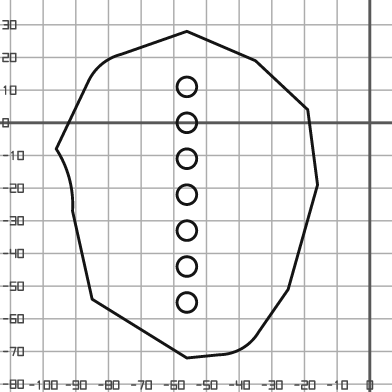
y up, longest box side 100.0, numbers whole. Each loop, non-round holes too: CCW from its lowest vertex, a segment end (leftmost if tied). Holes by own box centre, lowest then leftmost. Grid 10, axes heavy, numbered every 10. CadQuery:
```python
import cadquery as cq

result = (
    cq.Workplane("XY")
    .moveTo(-56.0, -72.0)
    .lineTo(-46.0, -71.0)
    .threePointArc((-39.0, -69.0), (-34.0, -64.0))
    .lineTo(-25.0, -51.0)
    .lineTo(-16.0, -19.0)
    .lineTo(-19.0, 4.0)
    .lineTo(-35.0, 19.0)
    .lineTo(-56.0, 28.0)
    .lineTo(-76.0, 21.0)
    .threePointArc((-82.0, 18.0), (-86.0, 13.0))
    .lineTo(-96.0, -8.0)
    .threePointArc((-92.0, -17.0), (-91.0, -27.0))
    .lineTo(-85.0, -54.0)
    .close()
    .moveTo(-56.0, -55.0)
    .circle(3.0)
    .moveTo(-56.0, -44.0)
    .circle(3.0)
    .moveTo(-56.0, -33.0)
    .circle(3.0)
    .moveTo(-56.0, -22.0)
    .circle(3.0)
    .moveTo(-56.0, -11.0)
    .circle(3.0)
    .moveTo(-56.0, 0.0)
    .circle(3.0)
    .moveTo(-56.0, 11.0)
    .circle(3.0)
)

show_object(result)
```